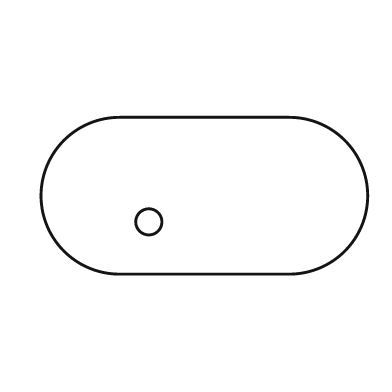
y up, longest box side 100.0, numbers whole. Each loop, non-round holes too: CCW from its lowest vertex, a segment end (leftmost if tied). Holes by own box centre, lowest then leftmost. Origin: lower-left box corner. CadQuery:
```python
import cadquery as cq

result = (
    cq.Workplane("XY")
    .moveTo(24.0, 0.0)
    .lineTo(76.0, 0.0)
    .threePointArc((100.0, 24.0), (76.0, 48.0))
    .lineTo(24.0, 48.0)
    .threePointArc((0.0, 24.0), (24.0, 0.0))
    .close()
    .moveTo(33.0, 16.0)
    .circle(4.0)
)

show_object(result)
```